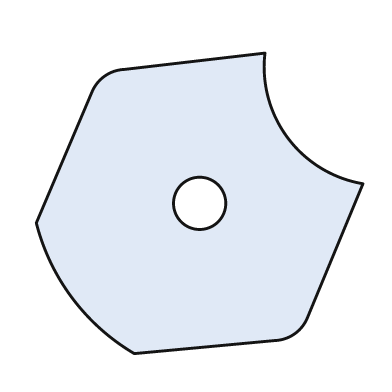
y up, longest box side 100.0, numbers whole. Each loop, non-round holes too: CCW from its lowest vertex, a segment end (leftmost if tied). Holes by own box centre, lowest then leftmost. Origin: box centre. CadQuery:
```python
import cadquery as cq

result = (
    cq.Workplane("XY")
    .moveTo(-20.0, -46.0)
    .lineTo(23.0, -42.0)
    .threePointArc((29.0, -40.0), (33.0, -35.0))
    .lineTo(50.0, 6.0)
    .threePointArc((27.0, 20.0), (20.0, 46.0))
    .lineTo(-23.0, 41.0)
    .threePointArc((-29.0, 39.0), (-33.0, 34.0))
    .lineTo(-50.0, -6.0)
    .threePointArc((-39.0, -29.0), (-20.0, -46.0))
    .close()
    .moveTo(0.0, 0.0)
    .circle(8.0)
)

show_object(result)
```